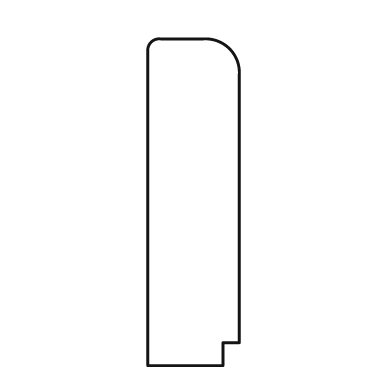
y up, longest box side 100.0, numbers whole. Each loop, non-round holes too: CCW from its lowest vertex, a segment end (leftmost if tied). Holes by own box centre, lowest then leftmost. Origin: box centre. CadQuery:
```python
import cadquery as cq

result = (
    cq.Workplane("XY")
    .moveTo(-14.0, -50.0)
    .lineTo(9.0, -50.0)
    .lineTo(9.0, -43.0)
    .lineTo(14.0, -43.0)
    .lineTo(14.0, 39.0)
    .threePointArc((11.0, 47.0), (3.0, 50.0))
    .lineTo(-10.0, 50.0)
    .threePointArc((-13.0, 49.0), (-14.0, 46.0))
    .close()
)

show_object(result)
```